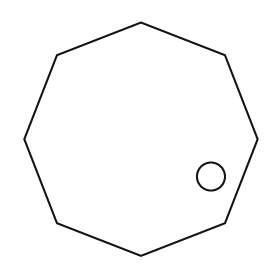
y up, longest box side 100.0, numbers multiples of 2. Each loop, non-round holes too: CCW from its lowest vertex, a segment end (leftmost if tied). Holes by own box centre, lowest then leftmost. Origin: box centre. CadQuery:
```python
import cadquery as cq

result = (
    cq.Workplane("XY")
    .moveTo(0.0, -50.0)
    .lineTo(36.0, -36.0)
    .lineTo(50.0, 0.0)
    .lineTo(36.0, 36.0)
    .lineTo(0.0, 50.0)
    .lineTo(-36.0, 36.0)
    .lineTo(-50.0, 0.0)
    .lineTo(-36.0, -36.0)
    .close()
    .moveTo(30.0, -16.0)
    .circle(6.0)
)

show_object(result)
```